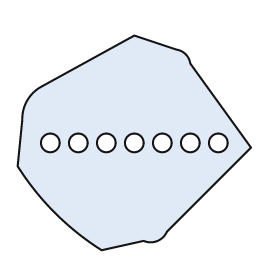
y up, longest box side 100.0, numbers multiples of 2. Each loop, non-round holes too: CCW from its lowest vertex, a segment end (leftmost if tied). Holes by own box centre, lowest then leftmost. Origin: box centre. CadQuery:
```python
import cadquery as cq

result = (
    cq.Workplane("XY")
    .moveTo(-14.0, -46.0)
    .lineTo(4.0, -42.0)
    .threePointArc((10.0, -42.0), (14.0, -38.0))
    .lineTo(50.0, -2.0)
    .lineTo(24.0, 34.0)
    .threePointArc((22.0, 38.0), (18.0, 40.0))
    .lineTo(0.0, 46.0)
    .lineTo(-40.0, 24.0)
    .threePointArc((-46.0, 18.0), (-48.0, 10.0))
    .lineTo(-50.0, -10.0)
    .threePointArc((-34.0, -30.0), (-14.0, -46.0))
    .close()
    .moveTo(-36.0, 0.0)
    .circle(4.0)
    .moveTo(-24.0, 0.0)
    .circle(4.0)
    .moveTo(-12.0, 0.0)
    .circle(4.0)
    .moveTo(0.0, 0.0)
    .circle(4.0)
    .moveTo(12.0, 0.0)
    .circle(4.0)
    .moveTo(24.0, 0.0)
    .circle(4.0)
    .moveTo(36.0, 0.0)
    .circle(4.0)
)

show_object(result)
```